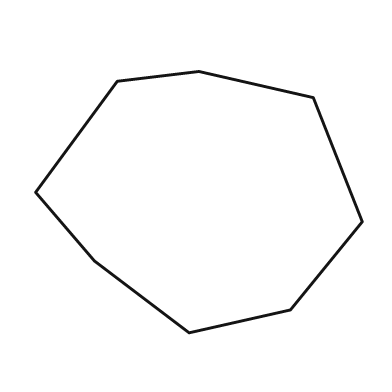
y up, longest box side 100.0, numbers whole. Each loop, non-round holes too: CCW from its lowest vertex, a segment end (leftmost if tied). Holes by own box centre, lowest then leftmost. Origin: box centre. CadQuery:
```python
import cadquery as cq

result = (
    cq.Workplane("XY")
    .moveTo(-3.0, -40.0)
    .lineTo(28.0, -33.0)
    .lineTo(50.0, -6.0)
    .lineTo(35.0, 32.0)
    .lineTo(0.0, 40.0)
    .lineTo(-25.0, 37.0)
    .lineTo(-50.0, 3.0)
    .lineTo(-32.0, -18.0)
    .close()
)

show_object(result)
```